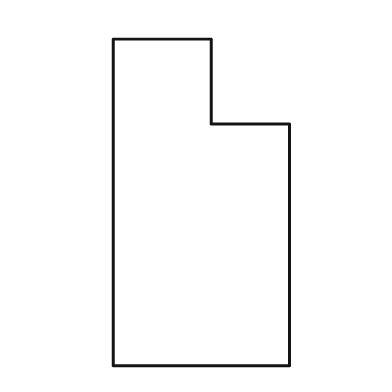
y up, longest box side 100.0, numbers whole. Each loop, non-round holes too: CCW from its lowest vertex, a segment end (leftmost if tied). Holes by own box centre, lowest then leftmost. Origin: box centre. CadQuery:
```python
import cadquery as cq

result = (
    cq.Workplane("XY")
    .moveTo(-27.0, -50.0)
    .lineTo(27.0, -50.0)
    .lineTo(27.0, 24.0)
    .lineTo(3.0, 24.0)
    .lineTo(3.0, 50.0)
    .lineTo(-27.0, 50.0)
    .close()
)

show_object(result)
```